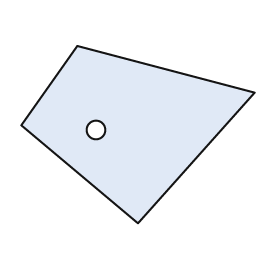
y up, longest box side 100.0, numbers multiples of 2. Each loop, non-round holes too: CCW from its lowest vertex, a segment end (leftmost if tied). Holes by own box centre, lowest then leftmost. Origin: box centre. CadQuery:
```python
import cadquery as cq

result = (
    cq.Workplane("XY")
    .moveTo(0.0, -38.0)
    .lineTo(50.0, 18.0)
    .lineTo(-26.0, 38.0)
    .lineTo(-50.0, 4.0)
    .close()
    .moveTo(-18.0, 2.0)
    .circle(4.0)
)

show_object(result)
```